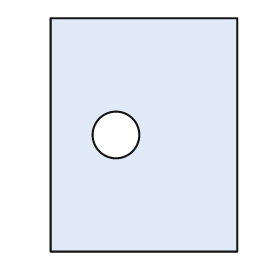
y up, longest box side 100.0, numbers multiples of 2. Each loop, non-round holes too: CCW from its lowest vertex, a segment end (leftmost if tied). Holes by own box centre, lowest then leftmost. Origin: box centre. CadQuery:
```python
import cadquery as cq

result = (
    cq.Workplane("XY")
    .moveTo(-40.0, -50.0)
    .lineTo(40.0, -50.0)
    .lineTo(40.0, 50.0)
    .lineTo(-40.0, 50.0)
    .close()
    .moveTo(-12.0, 0.0)
    .circle(10.0)
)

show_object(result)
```